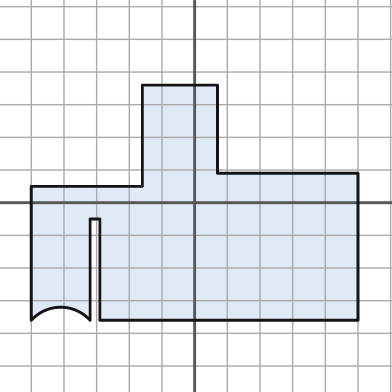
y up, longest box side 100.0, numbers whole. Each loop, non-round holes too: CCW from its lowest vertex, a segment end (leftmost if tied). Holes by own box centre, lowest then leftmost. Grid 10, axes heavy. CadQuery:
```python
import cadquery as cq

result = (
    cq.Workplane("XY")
    .moveTo(-50.0, -36.0)
    .threePointArc((-41.0, -32.0), (-32.0, -36.0))
    .lineTo(-32.0, -5.0)
    .lineTo(-29.0, -5.0)
    .lineTo(-29.0, -36.0)
    .lineTo(50.0, -36.0)
    .lineTo(50.0, 9.0)
    .lineTo(7.0, 9.0)
    .lineTo(7.0, 36.0)
    .lineTo(-16.0, 36.0)
    .lineTo(-16.0, 5.0)
    .lineTo(-50.0, 5.0)
    .close()
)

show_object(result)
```